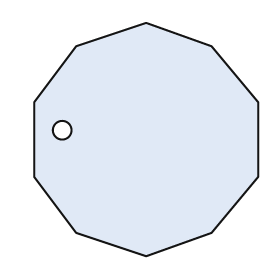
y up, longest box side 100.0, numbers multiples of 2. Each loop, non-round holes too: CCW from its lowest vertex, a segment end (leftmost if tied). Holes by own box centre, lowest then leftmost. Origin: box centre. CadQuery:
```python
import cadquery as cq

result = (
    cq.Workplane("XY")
    .moveTo(0.0, -50.0)
    .lineTo(28.0, -40.0)
    .lineTo(48.0, -16.0)
    .lineTo(48.0, 16.0)
    .lineTo(28.0, 40.0)
    .lineTo(0.0, 50.0)
    .lineTo(-30.0, 40.0)
    .lineTo(-48.0, 16.0)
    .lineTo(-48.0, -16.0)
    .lineTo(-30.0, -40.0)
    .close()
    .moveTo(-36.0, 4.0)
    .circle(4.0)
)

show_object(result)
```